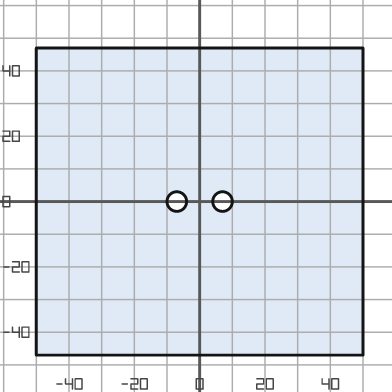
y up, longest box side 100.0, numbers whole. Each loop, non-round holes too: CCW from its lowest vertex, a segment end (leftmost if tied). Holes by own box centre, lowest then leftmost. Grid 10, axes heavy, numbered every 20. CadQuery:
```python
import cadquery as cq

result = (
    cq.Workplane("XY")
    .moveTo(-50.0, -47.0)
    .lineTo(50.0, -47.0)
    .lineTo(50.0, 47.0)
    .lineTo(-50.0, 47.0)
    .close()
    .moveTo(-7.0, 0.0)
    .circle(3.0)
    .moveTo(7.0, 0.0)
    .circle(3.0)
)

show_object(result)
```